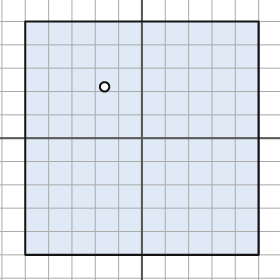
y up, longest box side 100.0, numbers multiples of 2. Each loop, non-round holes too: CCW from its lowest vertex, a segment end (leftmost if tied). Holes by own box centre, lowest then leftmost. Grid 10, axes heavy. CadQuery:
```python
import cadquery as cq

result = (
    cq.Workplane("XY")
    .moveTo(-50.0, -50.0)
    .lineTo(50.0, -50.0)
    .lineTo(50.0, 50.0)
    .lineTo(-50.0, 50.0)
    .close()
    .moveTo(-16.0, 22.0)
    .circle(2.0)
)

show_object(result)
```